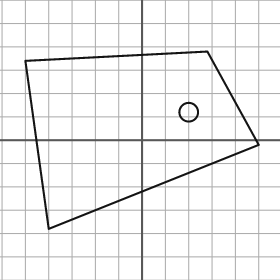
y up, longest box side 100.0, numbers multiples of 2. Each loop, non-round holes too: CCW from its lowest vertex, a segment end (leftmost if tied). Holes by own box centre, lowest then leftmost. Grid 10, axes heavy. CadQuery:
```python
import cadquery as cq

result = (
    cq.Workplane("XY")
    .moveTo(-40.0, -38.0)
    .lineTo(50.0, -2.0)
    .lineTo(28.0, 38.0)
    .lineTo(-50.0, 34.0)
    .close()
    .moveTo(20.0, 12.0)
    .circle(4.0)
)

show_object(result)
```